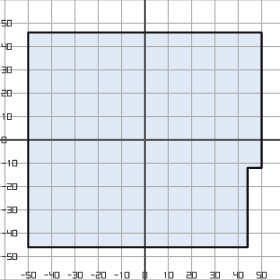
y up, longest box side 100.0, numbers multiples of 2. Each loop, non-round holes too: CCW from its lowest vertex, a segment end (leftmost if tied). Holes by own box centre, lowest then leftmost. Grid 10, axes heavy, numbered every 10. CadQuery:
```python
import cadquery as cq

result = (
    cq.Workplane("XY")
    .moveTo(-50.0, -46.0)
    .lineTo(44.0, -46.0)
    .lineTo(44.0, -12.0)
    .lineTo(50.0, -12.0)
    .lineTo(50.0, 46.0)
    .lineTo(-50.0, 46.0)
    .close()
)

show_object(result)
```